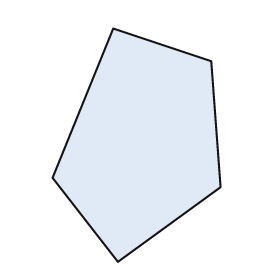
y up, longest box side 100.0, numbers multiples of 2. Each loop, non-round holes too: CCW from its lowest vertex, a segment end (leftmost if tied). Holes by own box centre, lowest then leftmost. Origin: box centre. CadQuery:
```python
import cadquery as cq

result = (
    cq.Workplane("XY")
    .moveTo(-8.0, -50.0)
    .lineTo(36.0, -18.0)
    .lineTo(32.0, 36.0)
    .lineTo(-10.0, 50.0)
    .lineTo(-36.0, -14.0)
    .close()
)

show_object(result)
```